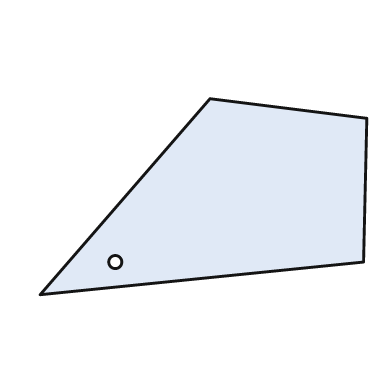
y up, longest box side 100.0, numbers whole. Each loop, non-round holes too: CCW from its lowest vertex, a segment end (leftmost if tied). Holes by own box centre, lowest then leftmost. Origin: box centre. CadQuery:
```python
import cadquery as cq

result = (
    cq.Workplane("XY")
    .moveTo(-50.0, -30.0)
    .lineTo(49.0, -20.0)
    .lineTo(50.0, 24.0)
    .lineTo(2.0, 30.0)
    .close()
    .moveTo(-27.0, -20.0)
    .circle(2.0)
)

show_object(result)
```